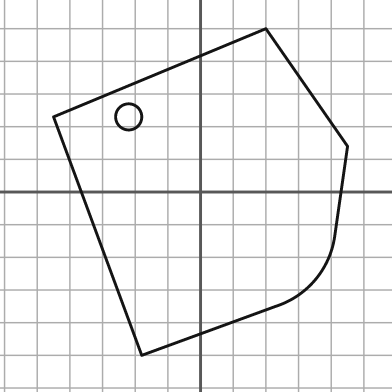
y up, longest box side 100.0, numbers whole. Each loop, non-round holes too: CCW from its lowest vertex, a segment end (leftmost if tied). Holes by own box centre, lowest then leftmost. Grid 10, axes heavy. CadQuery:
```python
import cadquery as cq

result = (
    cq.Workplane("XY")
    .moveTo(-18.0, -50.0)
    .lineTo(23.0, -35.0)
    .threePointArc((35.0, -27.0), (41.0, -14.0))
    .lineTo(45.0, 14.0)
    .lineTo(20.0, 50.0)
    .lineTo(-45.0, 23.0)
    .close()
    .moveTo(-22.0, 23.0)
    .circle(4.0)
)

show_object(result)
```